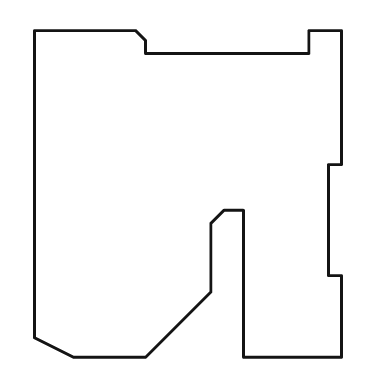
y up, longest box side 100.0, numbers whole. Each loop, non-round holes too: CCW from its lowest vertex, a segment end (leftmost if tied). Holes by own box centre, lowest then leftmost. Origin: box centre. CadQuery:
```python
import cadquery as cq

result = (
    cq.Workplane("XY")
    .moveTo(-35.0, -50.0)
    .lineTo(-13.0, -50.0)
    .lineTo(7.0, -30.0)
    .lineTo(7.0, -9.0)
    .lineTo(11.0, -5.0)
    .lineTo(17.0, -5.0)
    .lineTo(17.0, -50.0)
    .lineTo(47.0, -50.0)
    .lineTo(47.0, -25.0)
    .lineTo(43.0, -25.0)
    .lineTo(43.0, 9.0)
    .lineTo(47.0, 9.0)
    .lineTo(47.0, 50.0)
    .lineTo(37.0, 50.0)
    .lineTo(37.0, 43.0)
    .lineTo(-13.0, 43.0)
    .lineTo(-13.0, 47.0)
    .lineTo(-16.0, 50.0)
    .lineTo(-47.0, 50.0)
    .lineTo(-47.0, -44.0)
    .close()
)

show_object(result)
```